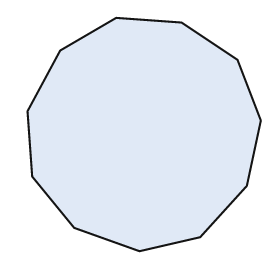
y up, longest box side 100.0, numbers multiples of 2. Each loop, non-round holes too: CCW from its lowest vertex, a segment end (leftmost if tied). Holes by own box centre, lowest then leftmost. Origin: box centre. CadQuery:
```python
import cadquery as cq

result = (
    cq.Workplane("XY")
    .moveTo(-2.0, -50.0)
    .lineTo(24.0, -44.0)
    .lineTo(44.0, -22.0)
    .lineTo(50.0, 6.0)
    .lineTo(40.0, 32.0)
    .lineTo(16.0, 48.0)
    .lineTo(-12.0, 50.0)
    .lineTo(-36.0, 36.0)
    .lineTo(-50.0, 10.0)
    .lineTo(-48.0, -18.0)
    .lineTo(-30.0, -40.0)
    .close()
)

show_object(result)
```